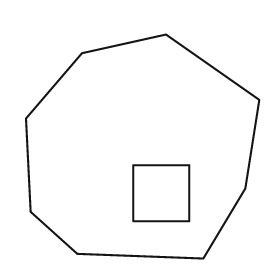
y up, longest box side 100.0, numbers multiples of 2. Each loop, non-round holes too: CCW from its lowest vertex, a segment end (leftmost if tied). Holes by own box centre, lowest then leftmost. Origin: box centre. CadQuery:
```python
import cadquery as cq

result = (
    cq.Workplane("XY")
    .moveTo(26.0, -48.0)
    .lineTo(44.0, -18.0)
    .lineTo(50.0, 20.0)
    .lineTo(10.0, 48.0)
    .lineTo(-26.0, 40.0)
    .lineTo(-50.0, 12.0)
    .lineTo(-48.0, -28.0)
    .lineTo(-28.0, -46.0)
    .close()
    .moveTo(-4.0, -32.0)
    .lineTo(20.0, -32.0)
    .lineTo(20.0, -8.0)
    .lineTo(-4.0, -8.0)
    .close()
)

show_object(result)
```